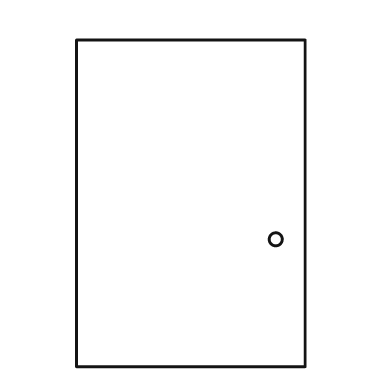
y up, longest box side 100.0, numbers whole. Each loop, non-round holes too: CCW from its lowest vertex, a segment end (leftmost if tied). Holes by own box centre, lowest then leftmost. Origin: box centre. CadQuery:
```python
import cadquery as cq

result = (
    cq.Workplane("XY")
    .moveTo(-35.0, -50.0)
    .lineTo(35.0, -50.0)
    .lineTo(35.0, 50.0)
    .lineTo(-35.0, 50.0)
    .close()
    .moveTo(26.0, -11.0)
    .circle(2.0)
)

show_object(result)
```